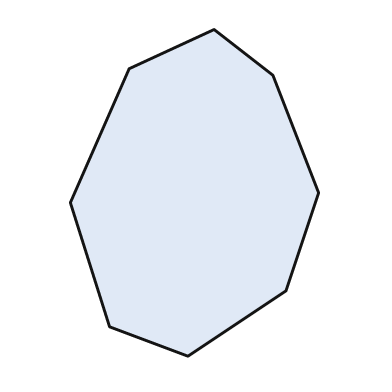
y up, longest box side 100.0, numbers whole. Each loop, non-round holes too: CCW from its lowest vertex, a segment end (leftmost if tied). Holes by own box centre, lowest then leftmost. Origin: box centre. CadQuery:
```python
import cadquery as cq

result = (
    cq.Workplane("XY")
    .moveTo(-2.0, -50.0)
    .lineTo(28.0, -30.0)
    .lineTo(38.0, 0.0)
    .lineTo(24.0, 36.0)
    .lineTo(6.0, 50.0)
    .lineTo(-20.0, 38.0)
    .lineTo(-38.0, -3.0)
    .lineTo(-26.0, -41.0)
    .close()
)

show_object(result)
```